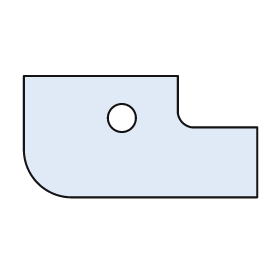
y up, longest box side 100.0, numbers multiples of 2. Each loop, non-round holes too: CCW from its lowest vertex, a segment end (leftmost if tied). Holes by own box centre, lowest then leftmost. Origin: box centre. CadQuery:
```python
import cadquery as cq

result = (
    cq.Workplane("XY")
    .moveTo(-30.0, -26.0)
    .lineTo(50.0, -26.0)
    .lineTo(50.0, 4.0)
    .lineTo(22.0, 4.0)
    .threePointArc((18.0, 6.0), (16.0, 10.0))
    .lineTo(16.0, 26.0)
    .lineTo(-50.0, 26.0)
    .lineTo(-50.0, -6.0)
    .threePointArc((-44.0, -20.0), (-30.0, -26.0))
    .close()
    .moveTo(-8.0, 8.0)
    .circle(6.0)
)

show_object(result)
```